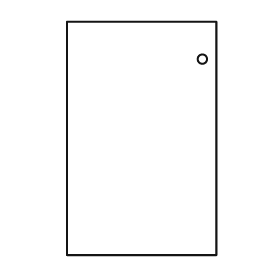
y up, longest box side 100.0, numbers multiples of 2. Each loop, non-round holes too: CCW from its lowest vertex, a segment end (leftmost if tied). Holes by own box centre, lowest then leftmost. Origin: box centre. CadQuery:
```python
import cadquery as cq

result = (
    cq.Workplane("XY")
    .moveTo(-32.0, -50.0)
    .lineTo(32.0, -50.0)
    .lineTo(32.0, 50.0)
    .lineTo(-32.0, 50.0)
    .close()
    .moveTo(26.0, 34.0)
    .circle(2.0)
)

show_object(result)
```